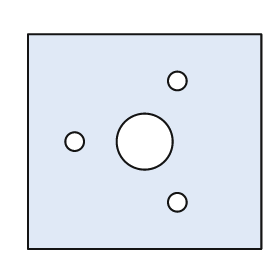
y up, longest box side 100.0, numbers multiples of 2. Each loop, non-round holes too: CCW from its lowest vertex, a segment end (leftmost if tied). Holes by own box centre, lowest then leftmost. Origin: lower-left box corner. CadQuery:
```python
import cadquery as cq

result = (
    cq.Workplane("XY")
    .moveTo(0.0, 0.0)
    .lineTo(100.0, 0.0)
    .lineTo(100.0, 92.0)
    .lineTo(0.0, 92.0)
    .close()
    .moveTo(64.0, 20.0)
    .circle(4.0)
    .moveTo(20.0, 46.0)
    .circle(4.0)
    .moveTo(50.0, 46.0)
    .circle(12.0)
    .moveTo(64.0, 72.0)
    .circle(4.0)
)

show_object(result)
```